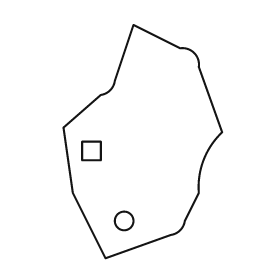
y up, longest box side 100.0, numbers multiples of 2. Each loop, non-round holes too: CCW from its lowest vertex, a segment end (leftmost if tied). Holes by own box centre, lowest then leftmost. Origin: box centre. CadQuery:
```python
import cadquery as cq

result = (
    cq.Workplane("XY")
    .moveTo(-16.0, -50.0)
    .lineTo(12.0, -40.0)
    .threePointArc((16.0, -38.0), (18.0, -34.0))
    .lineTo(24.0, -22.0)
    .threePointArc((26.0, -8.0), (34.0, 4.0))
    .lineTo(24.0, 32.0)
    .threePointArc((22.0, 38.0), (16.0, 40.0))
    .lineTo(-4.0, 50.0)
    .lineTo(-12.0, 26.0)
    .threePointArc((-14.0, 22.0), (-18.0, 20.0))
    .lineTo(-34.0, 6.0)
    .lineTo(-30.0, -22.0)
    .close()
    .moveTo(-8.0, -34.0)
    .circle(4.0)
    .moveTo(-26.0, -8.0)
    .lineTo(-18.0, -8.0)
    .lineTo(-18.0, 0.0)
    .lineTo(-26.0, 0.0)
    .close()
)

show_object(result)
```